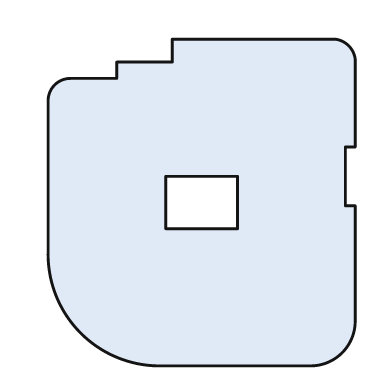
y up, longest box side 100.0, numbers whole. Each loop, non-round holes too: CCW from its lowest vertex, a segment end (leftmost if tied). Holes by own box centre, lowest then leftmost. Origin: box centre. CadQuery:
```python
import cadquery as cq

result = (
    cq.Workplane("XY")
    .moveTo(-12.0, -50.0)
    .lineTo(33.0, -50.0)
    .threePointArc((43.0, -46.0), (47.0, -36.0))
    .lineTo(47.0, -1.0)
    .lineTo(44.0, -1.0)
    .lineTo(44.0, 17.0)
    .lineTo(47.0, 17.0)
    .lineTo(47.0, 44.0)
    .threePointArc((45.0, 48.0), (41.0, 50.0))
    .lineTo(-9.0, 50.0)
    .lineTo(-9.0, 43.0)
    .lineTo(-26.0, 43.0)
    .lineTo(-26.0, 38.0)
    .lineTo(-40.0, 38.0)
    .threePointArc((-45.0, 36.0), (-47.0, 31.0))
    .lineTo(-47.0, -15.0)
    .threePointArc((-37.0, -40.0), (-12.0, -50.0))
    .close()
    .moveTo(-11.0, -8.0)
    .lineTo(11.0, -8.0)
    .lineTo(11.0, 8.0)
    .lineTo(-11.0, 8.0)
    .close()
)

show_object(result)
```